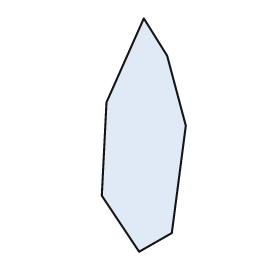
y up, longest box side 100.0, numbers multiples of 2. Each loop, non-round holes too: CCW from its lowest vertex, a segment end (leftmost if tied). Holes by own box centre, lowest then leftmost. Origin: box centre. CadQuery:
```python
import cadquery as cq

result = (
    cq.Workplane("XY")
    .moveTo(-2.0, -50.0)
    .lineTo(12.0, -42.0)
    .lineTo(18.0, 4.0)
    .lineTo(10.0, 34.0)
    .lineTo(0.0, 50.0)
    .lineTo(-16.0, 14.0)
    .lineTo(-18.0, -26.0)
    .close()
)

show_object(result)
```